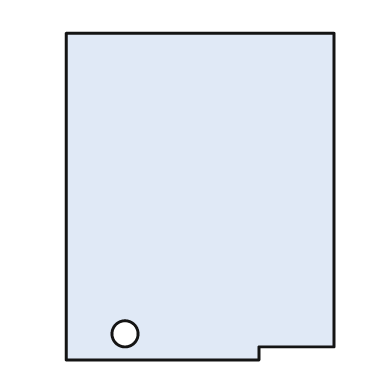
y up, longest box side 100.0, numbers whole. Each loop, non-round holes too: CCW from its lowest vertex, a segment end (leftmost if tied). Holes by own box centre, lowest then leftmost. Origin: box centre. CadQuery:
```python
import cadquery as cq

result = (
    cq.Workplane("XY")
    .moveTo(-41.0, -50.0)
    .lineTo(18.0, -50.0)
    .lineTo(18.0, -46.0)
    .lineTo(41.0, -46.0)
    .lineTo(41.0, 50.0)
    .lineTo(-41.0, 50.0)
    .close()
    .moveTo(-23.0, -42.0)
    .circle(4.0)
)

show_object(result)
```